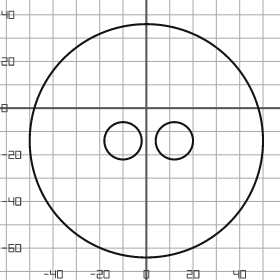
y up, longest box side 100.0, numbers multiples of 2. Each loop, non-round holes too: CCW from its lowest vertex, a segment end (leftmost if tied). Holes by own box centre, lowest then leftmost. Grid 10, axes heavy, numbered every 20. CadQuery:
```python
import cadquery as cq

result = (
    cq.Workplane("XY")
    .moveTo(0.0, -14.0)
    .circle(50.0)
    .moveTo(-10.0, -14.0)
    .circle(8.0)
    .moveTo(12.0, -14.0)
    .circle(8.0)
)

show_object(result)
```